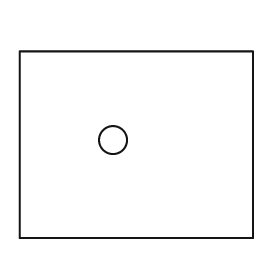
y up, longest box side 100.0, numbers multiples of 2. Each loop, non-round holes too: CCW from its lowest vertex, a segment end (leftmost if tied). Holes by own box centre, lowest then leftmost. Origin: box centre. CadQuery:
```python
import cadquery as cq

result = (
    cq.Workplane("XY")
    .moveTo(-50.0, -40.0)
    .lineTo(50.0, -40.0)
    .lineTo(50.0, 40.0)
    .lineTo(-50.0, 40.0)
    .close()
    .moveTo(-10.0, 2.0)
    .circle(6.0)
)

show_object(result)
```